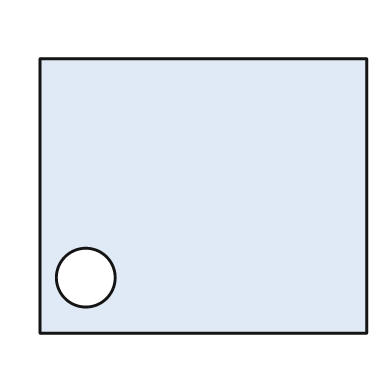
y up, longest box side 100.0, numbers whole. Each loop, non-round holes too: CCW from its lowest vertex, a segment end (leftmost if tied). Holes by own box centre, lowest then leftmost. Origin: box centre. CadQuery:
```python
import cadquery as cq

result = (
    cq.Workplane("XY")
    .moveTo(-50.0, -42.0)
    .lineTo(50.0, -42.0)
    .lineTo(50.0, 42.0)
    .lineTo(-50.0, 42.0)
    .close()
    .moveTo(-36.0, -25.0)
    .circle(9.0)
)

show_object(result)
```